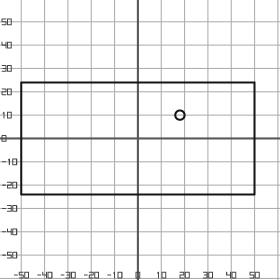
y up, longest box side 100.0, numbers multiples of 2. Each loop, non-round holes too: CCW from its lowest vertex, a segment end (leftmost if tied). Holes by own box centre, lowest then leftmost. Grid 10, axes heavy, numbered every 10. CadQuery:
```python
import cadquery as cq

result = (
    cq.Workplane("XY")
    .moveTo(-50.0, -24.0)
    .lineTo(50.0, -24.0)
    .lineTo(50.0, 24.0)
    .lineTo(-50.0, 24.0)
    .close()
    .moveTo(18.0, 10.0)
    .circle(2.0)
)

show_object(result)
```